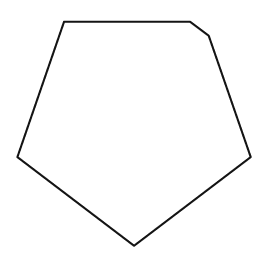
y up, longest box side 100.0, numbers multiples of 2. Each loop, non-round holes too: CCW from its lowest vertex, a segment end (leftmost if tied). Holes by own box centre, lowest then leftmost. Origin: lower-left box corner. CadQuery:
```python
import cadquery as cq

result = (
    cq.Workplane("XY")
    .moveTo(50.0, 0.0)
    .lineTo(100.0, 38.0)
    .lineTo(82.0, 90.0)
    .lineTo(74.0, 96.0)
    .lineTo(20.0, 96.0)
    .lineTo(0.0, 38.0)
    .close()
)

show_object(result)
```